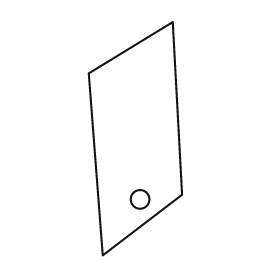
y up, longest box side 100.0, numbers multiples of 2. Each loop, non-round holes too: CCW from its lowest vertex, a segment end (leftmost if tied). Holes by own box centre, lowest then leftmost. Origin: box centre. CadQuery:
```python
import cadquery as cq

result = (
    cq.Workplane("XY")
    .moveTo(-14.0, -50.0)
    .lineTo(20.0, -24.0)
    .lineTo(16.0, 50.0)
    .lineTo(-20.0, 28.0)
    .close()
    .moveTo(2.0, -26.0)
    .circle(4.0)
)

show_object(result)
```